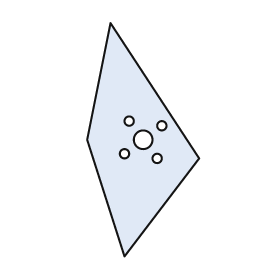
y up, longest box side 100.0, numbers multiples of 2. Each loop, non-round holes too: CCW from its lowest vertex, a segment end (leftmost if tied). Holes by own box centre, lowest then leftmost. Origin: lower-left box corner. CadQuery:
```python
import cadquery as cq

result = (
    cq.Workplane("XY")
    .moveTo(16.0, 0.0)
    .lineTo(48.0, 42.0)
    .lineTo(10.0, 100.0)
    .lineTo(0.0, 50.0)
    .close()
    .moveTo(30.0, 42.0)
    .circle(2.0)
    .moveTo(16.0, 44.0)
    .circle(2.0)
    .moveTo(24.0, 50.0)
    .circle(4.0)
    .moveTo(32.0, 56.0)
    .circle(2.0)
    .moveTo(18.0, 58.0)
    .circle(2.0)
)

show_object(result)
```